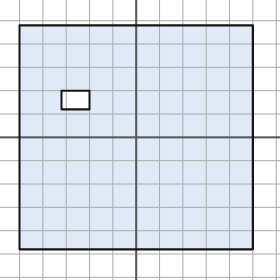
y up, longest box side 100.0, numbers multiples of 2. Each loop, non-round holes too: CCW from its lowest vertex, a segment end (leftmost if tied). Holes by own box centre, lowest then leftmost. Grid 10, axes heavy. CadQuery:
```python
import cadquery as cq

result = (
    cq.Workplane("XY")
    .moveTo(-50.0, -48.0)
    .lineTo(50.0, -48.0)
    .lineTo(50.0, 48.0)
    .lineTo(-50.0, 48.0)
    .close()
    .moveTo(-32.0, 12.0)
    .lineTo(-20.0, 12.0)
    .lineTo(-20.0, 20.0)
    .lineTo(-32.0, 20.0)
    .close()
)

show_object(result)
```